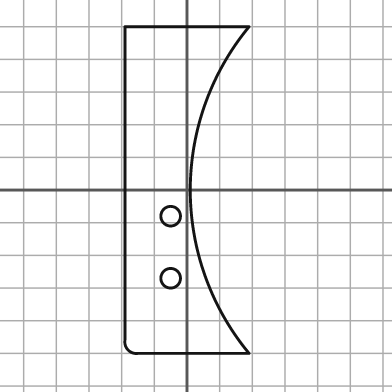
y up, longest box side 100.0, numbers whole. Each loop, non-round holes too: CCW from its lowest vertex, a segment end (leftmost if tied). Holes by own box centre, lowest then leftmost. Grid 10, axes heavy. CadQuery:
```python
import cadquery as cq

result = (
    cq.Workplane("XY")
    .moveTo(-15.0, -50.0)
    .lineTo(19.0, -50.0)
    .threePointArc((1.0, 0.0), (19.0, 50.0))
    .lineTo(-19.0, 50.0)
    .lineTo(-19.0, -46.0)
    .threePointArc((-18.0, -49.0), (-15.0, -50.0))
    .close()
    .moveTo(-5.0, -27.0)
    .circle(3.0)
    .moveTo(-5.0, -8.0)
    .circle(3.0)
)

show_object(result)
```